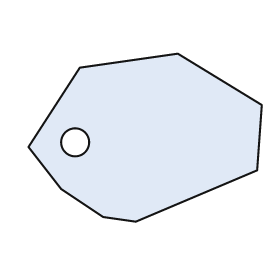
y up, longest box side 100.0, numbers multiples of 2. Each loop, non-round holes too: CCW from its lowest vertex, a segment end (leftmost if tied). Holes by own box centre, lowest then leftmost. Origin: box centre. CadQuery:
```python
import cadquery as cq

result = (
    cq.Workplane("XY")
    .moveTo(-4.0, -36.0)
    .lineTo(48.0, -14.0)
    .lineTo(50.0, 14.0)
    .lineTo(14.0, 36.0)
    .lineTo(-28.0, 30.0)
    .lineTo(-50.0, -4.0)
    .lineTo(-36.0, -22.0)
    .lineTo(-18.0, -34.0)
    .close()
    .moveTo(-30.0, -2.0)
    .circle(6.0)
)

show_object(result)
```